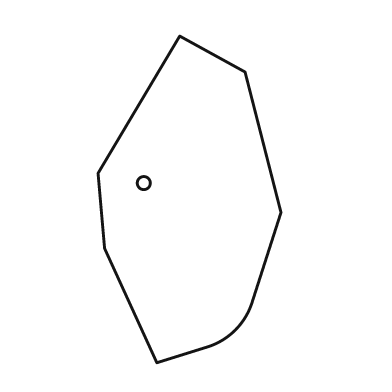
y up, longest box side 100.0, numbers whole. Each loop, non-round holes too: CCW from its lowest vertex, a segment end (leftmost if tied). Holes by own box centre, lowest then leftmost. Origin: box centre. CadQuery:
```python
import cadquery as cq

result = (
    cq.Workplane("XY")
    .moveTo(-10.0, -50.0)
    .lineTo(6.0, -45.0)
    .threePointArc((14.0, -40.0), (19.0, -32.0))
    .lineTo(28.0, -4.0)
    .lineTo(17.0, 39.0)
    .lineTo(-3.0, 50.0)
    .lineTo(-28.0, 8.0)
    .lineTo(-26.0, -15.0)
    .close()
    .moveTo(-14.0, 5.0)
    .circle(2.0)
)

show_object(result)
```